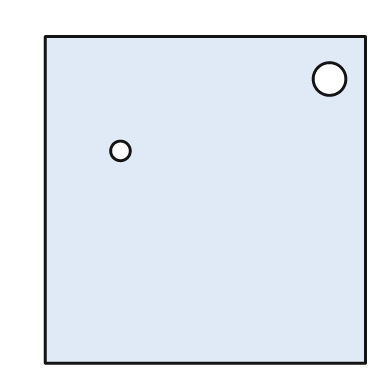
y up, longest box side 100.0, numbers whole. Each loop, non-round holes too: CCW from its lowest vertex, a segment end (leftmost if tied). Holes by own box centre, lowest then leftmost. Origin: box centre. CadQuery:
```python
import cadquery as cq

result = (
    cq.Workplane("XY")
    .moveTo(-49.0, -50.0)
    .lineTo(49.0, -50.0)
    .lineTo(49.0, 50.0)
    .lineTo(-49.0, 50.0)
    .close()
    .moveTo(-26.0, 15.0)
    .circle(3.0)
    .moveTo(38.0, 37.0)
    .circle(5.0)
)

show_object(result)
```